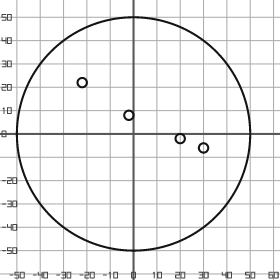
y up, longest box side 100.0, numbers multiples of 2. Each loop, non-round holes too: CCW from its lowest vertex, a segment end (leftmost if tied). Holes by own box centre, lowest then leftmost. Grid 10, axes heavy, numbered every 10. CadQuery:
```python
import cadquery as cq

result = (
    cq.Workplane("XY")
    .moveTo(0.0, 0.0)
    .circle(50.0)
    .moveTo(30.0, -6.0)
    .circle(2.0)
    .moveTo(20.0, -2.0)
    .circle(2.0)
    .moveTo(-2.0, 8.0)
    .circle(2.0)
    .moveTo(-22.0, 22.0)
    .circle(2.0)
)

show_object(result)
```